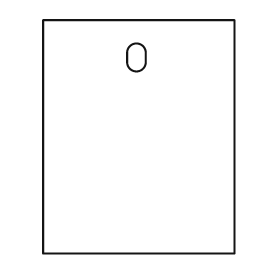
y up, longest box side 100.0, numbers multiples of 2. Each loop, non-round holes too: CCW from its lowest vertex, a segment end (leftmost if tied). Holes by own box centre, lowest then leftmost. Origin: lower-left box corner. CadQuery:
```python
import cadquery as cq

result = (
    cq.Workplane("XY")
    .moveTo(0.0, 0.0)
    .lineTo(82.0, 0.0)
    .lineTo(82.0, 100.0)
    .lineTo(0.0, 100.0)
    .close()
    .moveTo(36.0, 82.0)
    .threePointArc((40.0, 78.0), (44.0, 82.0))
    .lineTo(44.0, 86.0)
    .threePointArc((40.0, 90.0), (36.0, 86.0))
    .close()
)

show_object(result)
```